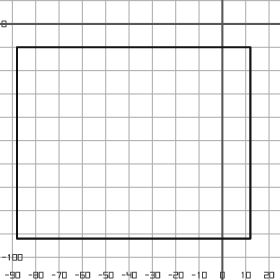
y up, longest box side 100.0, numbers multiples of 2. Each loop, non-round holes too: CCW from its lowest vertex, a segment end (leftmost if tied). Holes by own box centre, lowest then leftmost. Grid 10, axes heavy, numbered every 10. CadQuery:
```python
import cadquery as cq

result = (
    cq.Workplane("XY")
    .moveTo(-88.0, -92.0)
    .lineTo(12.0, -92.0)
    .lineTo(12.0, -10.0)
    .lineTo(-88.0, -10.0)
    .close()
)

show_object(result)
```